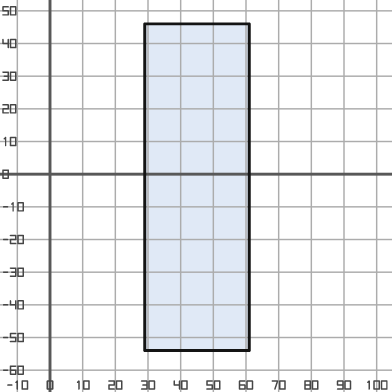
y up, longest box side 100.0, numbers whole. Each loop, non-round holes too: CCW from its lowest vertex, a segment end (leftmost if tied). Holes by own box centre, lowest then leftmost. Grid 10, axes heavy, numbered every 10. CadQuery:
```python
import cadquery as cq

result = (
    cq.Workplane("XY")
    .moveTo(29.0, -54.0)
    .lineTo(61.0, -54.0)
    .lineTo(61.0, 46.0)
    .lineTo(29.0, 46.0)
    .close()
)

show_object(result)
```